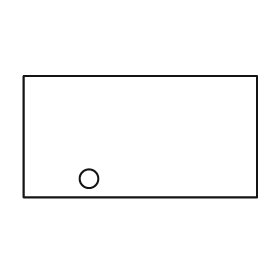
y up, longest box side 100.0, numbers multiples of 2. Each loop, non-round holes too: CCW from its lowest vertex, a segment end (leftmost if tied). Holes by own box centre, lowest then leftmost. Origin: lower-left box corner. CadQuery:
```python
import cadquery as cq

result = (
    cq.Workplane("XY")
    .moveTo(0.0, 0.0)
    .lineTo(100.0, 0.0)
    .lineTo(100.0, 52.0)
    .lineTo(0.0, 52.0)
    .close()
    .moveTo(28.0, 8.0)
    .circle(4.0)
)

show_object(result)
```